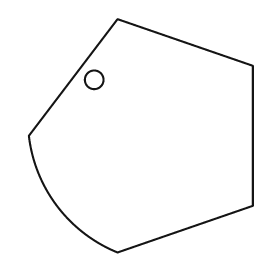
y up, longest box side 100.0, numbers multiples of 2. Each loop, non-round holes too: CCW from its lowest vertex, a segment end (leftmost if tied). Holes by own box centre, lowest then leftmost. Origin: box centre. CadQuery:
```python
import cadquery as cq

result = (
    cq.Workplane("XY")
    .moveTo(-10.0, -50.0)
    .lineTo(48.0, -30.0)
    .lineTo(48.0, 30.0)
    .lineTo(-10.0, 50.0)
    .lineTo(-48.0, 0.0)
    .threePointArc((-36.0, -30.0), (-10.0, -50.0))
    .close()
    .moveTo(-20.0, 24.0)
    .circle(4.0)
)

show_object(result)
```